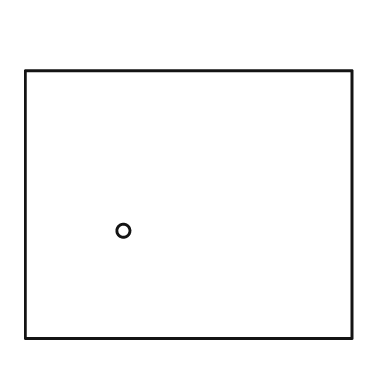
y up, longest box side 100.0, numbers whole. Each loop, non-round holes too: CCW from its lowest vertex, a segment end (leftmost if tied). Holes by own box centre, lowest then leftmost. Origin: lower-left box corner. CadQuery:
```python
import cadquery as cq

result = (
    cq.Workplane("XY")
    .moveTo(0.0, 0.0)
    .lineTo(100.0, 0.0)
    .lineTo(100.0, 82.0)
    .lineTo(0.0, 82.0)
    .close()
    .moveTo(30.0, 33.0)
    .circle(2.0)
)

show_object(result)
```